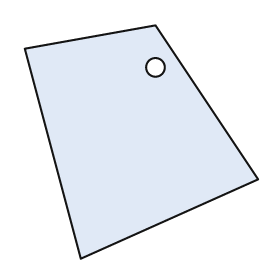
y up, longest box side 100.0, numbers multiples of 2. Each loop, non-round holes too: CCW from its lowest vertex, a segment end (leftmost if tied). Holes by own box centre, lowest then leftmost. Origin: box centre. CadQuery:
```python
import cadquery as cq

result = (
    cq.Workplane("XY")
    .moveTo(-26.0, -50.0)
    .lineTo(50.0, -16.0)
    .lineTo(6.0, 50.0)
    .lineTo(-50.0, 40.0)
    .close()
    .moveTo(6.0, 32.0)
    .circle(4.0)
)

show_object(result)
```